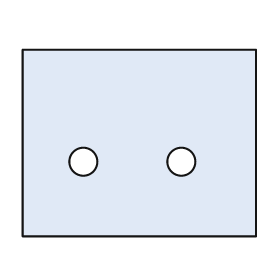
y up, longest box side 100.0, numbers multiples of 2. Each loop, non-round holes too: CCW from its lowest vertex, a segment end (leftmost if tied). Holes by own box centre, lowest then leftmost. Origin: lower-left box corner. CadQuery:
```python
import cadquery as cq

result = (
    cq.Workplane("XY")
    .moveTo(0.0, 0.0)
    .lineTo(100.0, 0.0)
    .lineTo(100.0, 80.0)
    .lineTo(0.0, 80.0)
    .close()
    .moveTo(26.0, 32.0)
    .circle(6.0)
    .moveTo(68.0, 32.0)
    .circle(6.0)
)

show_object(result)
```